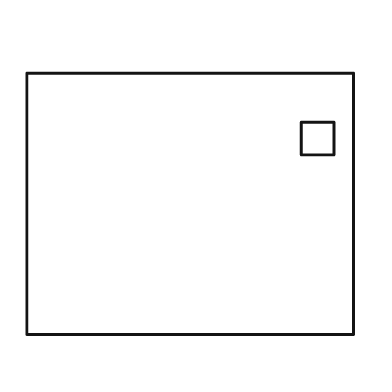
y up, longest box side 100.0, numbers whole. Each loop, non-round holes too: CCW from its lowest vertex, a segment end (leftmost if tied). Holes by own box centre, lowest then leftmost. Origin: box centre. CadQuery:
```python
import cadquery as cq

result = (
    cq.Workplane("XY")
    .moveTo(-50.0, -40.0)
    .lineTo(50.0, -40.0)
    .lineTo(50.0, 40.0)
    .lineTo(-50.0, 40.0)
    .close()
    .moveTo(34.0, 15.0)
    .lineTo(44.0, 15.0)
    .lineTo(44.0, 25.0)
    .lineTo(34.0, 25.0)
    .close()
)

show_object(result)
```